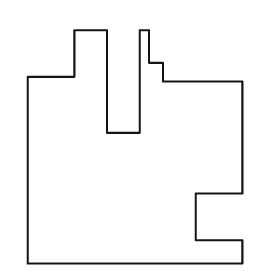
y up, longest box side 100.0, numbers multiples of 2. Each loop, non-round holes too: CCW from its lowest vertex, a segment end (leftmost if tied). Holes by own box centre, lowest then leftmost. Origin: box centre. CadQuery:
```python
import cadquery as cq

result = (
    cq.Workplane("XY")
    .moveTo(-46.0, -50.0)
    .lineTo(46.0, -50.0)
    .lineTo(46.0, -40.0)
    .lineTo(26.0, -40.0)
    .lineTo(26.0, -20.0)
    .lineTo(46.0, -20.0)
    .lineTo(46.0, 28.0)
    .lineTo(12.0, 28.0)
    .lineTo(12.0, 36.0)
    .lineTo(6.0, 36.0)
    .lineTo(6.0, 50.0)
    .lineTo(2.0, 50.0)
    .lineTo(2.0, 6.0)
    .lineTo(-12.0, 6.0)
    .lineTo(-12.0, 50.0)
    .lineTo(-26.0, 50.0)
    .lineTo(-26.0, 30.0)
    .lineTo(-46.0, 30.0)
    .close()
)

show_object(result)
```